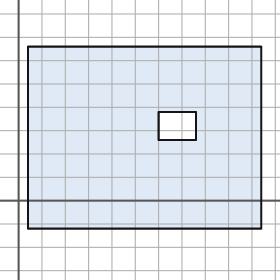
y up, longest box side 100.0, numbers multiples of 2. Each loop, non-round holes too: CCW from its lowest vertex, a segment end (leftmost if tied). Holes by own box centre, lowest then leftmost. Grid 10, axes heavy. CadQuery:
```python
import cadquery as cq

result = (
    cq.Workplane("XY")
    .moveTo(4.0, -12.0)
    .lineTo(104.0, -12.0)
    .lineTo(104.0, 66.0)
    .lineTo(4.0, 66.0)
    .close()
    .moveTo(60.0, 26.0)
    .lineTo(76.0, 26.0)
    .lineTo(76.0, 38.0)
    .lineTo(60.0, 38.0)
    .close()
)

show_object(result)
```